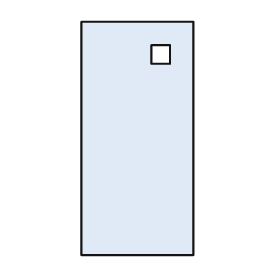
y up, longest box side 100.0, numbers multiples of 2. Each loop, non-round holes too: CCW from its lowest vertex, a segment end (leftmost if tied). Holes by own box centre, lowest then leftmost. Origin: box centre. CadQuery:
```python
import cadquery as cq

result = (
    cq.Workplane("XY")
    .moveTo(-24.0, -50.0)
    .lineTo(24.0, -50.0)
    .lineTo(24.0, 50.0)
    .lineTo(-24.0, 50.0)
    .close()
    .moveTo(6.0, 32.0)
    .lineTo(14.0, 32.0)
    .lineTo(14.0, 40.0)
    .lineTo(6.0, 40.0)
    .close()
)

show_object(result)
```